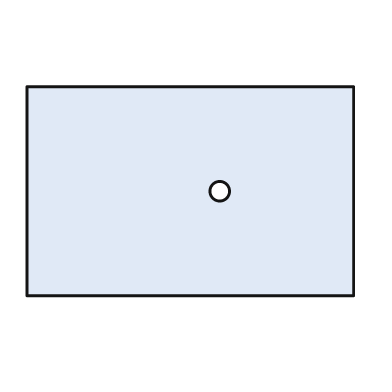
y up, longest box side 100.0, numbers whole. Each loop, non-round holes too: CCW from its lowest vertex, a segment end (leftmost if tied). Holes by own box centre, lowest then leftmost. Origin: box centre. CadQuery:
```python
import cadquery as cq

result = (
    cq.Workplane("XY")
    .moveTo(-50.0, -32.0)
    .lineTo(50.0, -32.0)
    .lineTo(50.0, 32.0)
    .lineTo(-50.0, 32.0)
    .close()
    .moveTo(9.0, 0.0)
    .circle(3.0)
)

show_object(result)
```